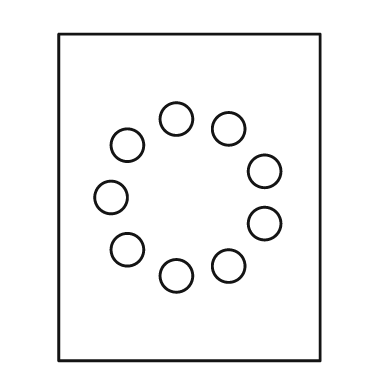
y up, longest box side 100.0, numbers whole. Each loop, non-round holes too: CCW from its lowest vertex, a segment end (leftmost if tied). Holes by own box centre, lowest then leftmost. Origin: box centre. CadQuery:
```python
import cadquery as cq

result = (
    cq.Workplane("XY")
    .moveTo(-40.0, -50.0)
    .lineTo(40.0, -50.0)
    .lineTo(40.0, 50.0)
    .lineTo(-40.0, 50.0)
    .close()
    .moveTo(-4.0, -24.0)
    .circle(5.0)
    .moveTo(12.0, -21.0)
    .circle(5.0)
    .moveTo(-19.0, -16.0)
    .circle(5.0)
    .moveTo(23.0, -8.0)
    .circle(5.0)
    .moveTo(-24.0, 0.0)
    .circle(5.0)
    .moveTo(23.0, 8.0)
    .circle(5.0)
    .moveTo(-19.0, 16.0)
    .circle(5.0)
    .moveTo(12.0, 21.0)
    .circle(5.0)
    .moveTo(-4.0, 24.0)
    .circle(5.0)
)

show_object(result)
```